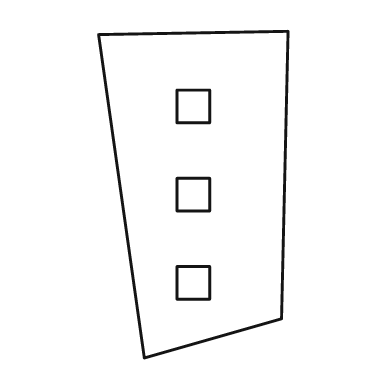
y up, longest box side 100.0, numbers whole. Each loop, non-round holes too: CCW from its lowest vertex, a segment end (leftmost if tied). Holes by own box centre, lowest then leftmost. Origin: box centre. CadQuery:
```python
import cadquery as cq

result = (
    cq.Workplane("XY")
    .moveTo(-15.0, -50.0)
    .lineTo(27.0, -38.0)
    .lineTo(29.0, 50.0)
    .lineTo(-29.0, 49.0)
    .close()
    .moveTo(-5.0, -32.0)
    .lineTo(5.0, -32.0)
    .lineTo(5.0, -22.0)
    .lineTo(-5.0, -22.0)
    .close()
    .moveTo(-5.0, -5.0)
    .lineTo(5.0, -5.0)
    .lineTo(5.0, 5.0)
    .lineTo(-5.0, 5.0)
    .close()
    .moveTo(-5.0, 22.0)
    .lineTo(5.0, 22.0)
    .lineTo(5.0, 32.0)
    .lineTo(-5.0, 32.0)
    .close()
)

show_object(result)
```